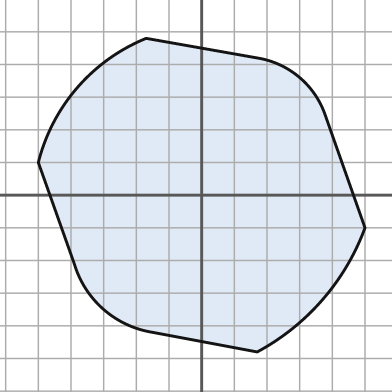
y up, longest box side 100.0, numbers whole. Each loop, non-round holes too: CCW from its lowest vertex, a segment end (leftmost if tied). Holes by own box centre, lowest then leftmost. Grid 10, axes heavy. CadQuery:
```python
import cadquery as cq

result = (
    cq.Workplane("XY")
    .moveTo(17.0, -48.0)
    .threePointArc((37.0, -32.0), (50.0, -10.0))
    .lineTo(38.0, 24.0)
    .threePointArc((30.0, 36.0), (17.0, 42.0))
    .lineTo(-17.0, 48.0)
    .threePointArc((-38.0, 33.0), (-50.0, 10.0))
    .lineTo(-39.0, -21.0)
    .threePointArc((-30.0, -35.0), (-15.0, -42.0))
    .close()
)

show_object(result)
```